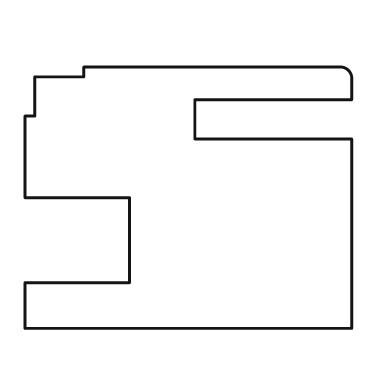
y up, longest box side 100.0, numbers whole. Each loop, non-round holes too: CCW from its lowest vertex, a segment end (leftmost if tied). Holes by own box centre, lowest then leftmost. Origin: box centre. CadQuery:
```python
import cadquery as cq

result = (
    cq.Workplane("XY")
    .moveTo(-50.0, -40.0)
    .lineTo(50.0, -40.0)
    .lineTo(50.0, 18.0)
    .lineTo(2.0, 18.0)
    .lineTo(2.0, 30.0)
    .lineTo(50.0, 30.0)
    .lineTo(50.0, 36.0)
    .threePointArc((49.0, 39.0), (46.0, 40.0))
    .lineTo(-32.0, 40.0)
    .lineTo(-32.0, 37.0)
    .lineTo(-47.0, 37.0)
    .lineTo(-47.0, 25.0)
    .lineTo(-50.0, 25.0)
    .lineTo(-50.0, 0.0)
    .lineTo(-18.0, 0.0)
    .lineTo(-18.0, -26.0)
    .lineTo(-50.0, -26.0)
    .close()
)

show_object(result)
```